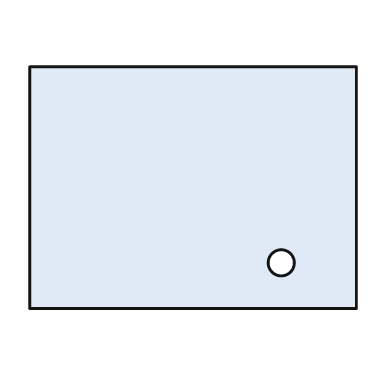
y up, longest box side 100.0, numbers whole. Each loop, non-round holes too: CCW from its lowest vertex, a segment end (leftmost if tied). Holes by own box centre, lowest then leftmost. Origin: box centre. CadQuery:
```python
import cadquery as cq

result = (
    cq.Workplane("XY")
    .moveTo(-50.0, -37.0)
    .lineTo(50.0, -37.0)
    .lineTo(50.0, 37.0)
    .lineTo(-50.0, 37.0)
    .close()
    .moveTo(27.0, -23.0)
    .circle(4.0)
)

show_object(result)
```